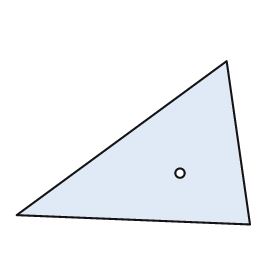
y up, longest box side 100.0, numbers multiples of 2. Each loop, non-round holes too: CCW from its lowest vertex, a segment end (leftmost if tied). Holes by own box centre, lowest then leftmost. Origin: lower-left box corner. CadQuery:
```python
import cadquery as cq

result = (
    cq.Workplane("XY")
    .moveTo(100.0, 0.0)
    .lineTo(90.0, 70.0)
    .lineTo(0.0, 4.0)
    .close()
    .moveTo(70.0, 22.0)
    .circle(2.0)
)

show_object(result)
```